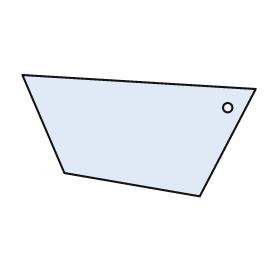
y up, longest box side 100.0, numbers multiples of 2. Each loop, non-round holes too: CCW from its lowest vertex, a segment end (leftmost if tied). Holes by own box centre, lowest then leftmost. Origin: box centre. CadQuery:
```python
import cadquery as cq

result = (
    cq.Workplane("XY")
    .moveTo(26.0, -26.0)
    .lineTo(50.0, 20.0)
    .lineTo(-50.0, 26.0)
    .lineTo(-32.0, -16.0)
    .close()
    .moveTo(38.0, 12.0)
    .circle(2.0)
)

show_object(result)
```